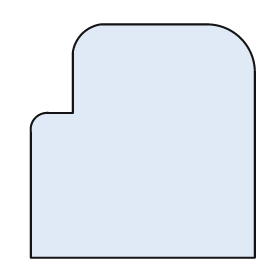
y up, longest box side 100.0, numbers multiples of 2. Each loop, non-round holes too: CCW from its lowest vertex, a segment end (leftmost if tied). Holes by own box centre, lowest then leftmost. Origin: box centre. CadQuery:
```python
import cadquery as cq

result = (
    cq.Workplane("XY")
    .moveTo(-48.0, -50.0)
    .lineTo(48.0, -50.0)
    .lineTo(48.0, 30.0)
    .threePointArc((42.0, 44.0), (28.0, 50.0))
    .lineTo(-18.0, 50.0)
    .threePointArc((-26.0, 46.0), (-30.0, 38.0))
    .lineTo(-30.0, 12.0)
    .lineTo(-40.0, 12.0)
    .threePointArc((-46.0, 10.0), (-48.0, 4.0))
    .close()
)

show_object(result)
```